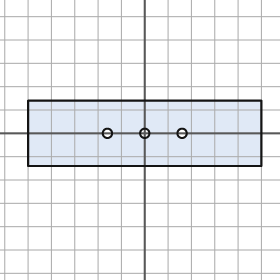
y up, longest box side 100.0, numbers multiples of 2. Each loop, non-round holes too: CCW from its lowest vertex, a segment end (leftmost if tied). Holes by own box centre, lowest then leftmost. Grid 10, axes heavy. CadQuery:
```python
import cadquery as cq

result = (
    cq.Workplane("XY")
    .moveTo(-50.0, -14.0)
    .lineTo(50.0, -14.0)
    .lineTo(50.0, 14.0)
    .lineTo(-50.0, 14.0)
    .close()
    .moveTo(-16.0, 0.0)
    .circle(2.0)
    .moveTo(0.0, 0.0)
    .circle(2.0)
    .moveTo(16.0, 0.0)
    .circle(2.0)
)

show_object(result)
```